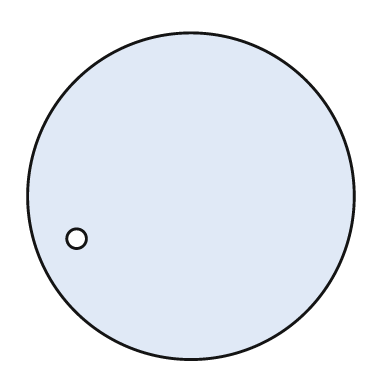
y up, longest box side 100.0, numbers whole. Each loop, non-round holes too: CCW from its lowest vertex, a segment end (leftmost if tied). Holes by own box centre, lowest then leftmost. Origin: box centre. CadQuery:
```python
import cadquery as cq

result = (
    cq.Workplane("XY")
    .moveTo(0.0, 0.0)
    .circle(50.0)
    .moveTo(-35.0, -13.0)
    .circle(3.0)
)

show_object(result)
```